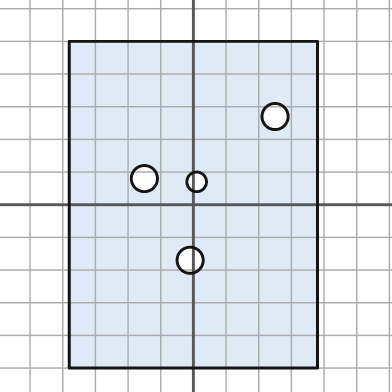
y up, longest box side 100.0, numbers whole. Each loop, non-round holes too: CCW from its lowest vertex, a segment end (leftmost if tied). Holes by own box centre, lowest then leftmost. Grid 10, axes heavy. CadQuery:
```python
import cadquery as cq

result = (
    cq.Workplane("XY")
    .moveTo(-38.0, -50.0)
    .lineTo(38.0, -50.0)
    .lineTo(38.0, 50.0)
    .lineTo(-38.0, 50.0)
    .close()
    .moveTo(-1.0, -17.0)
    .circle(4.0)
    .moveTo(1.0, 7.0)
    .circle(3.0)
    .moveTo(-15.0, 8.0)
    .circle(4.0)
    .moveTo(25.0, 27.0)
    .circle(4.0)
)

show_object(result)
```